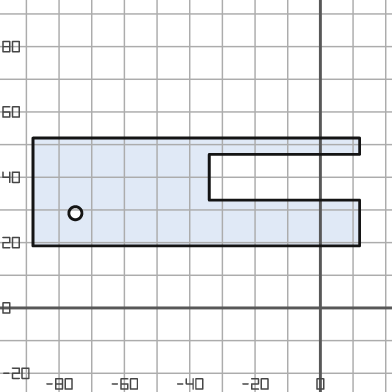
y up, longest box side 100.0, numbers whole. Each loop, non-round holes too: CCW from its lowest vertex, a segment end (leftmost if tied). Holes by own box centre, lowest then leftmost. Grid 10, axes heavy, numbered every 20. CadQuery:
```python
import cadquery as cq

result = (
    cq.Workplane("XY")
    .moveTo(-88.0, 19.0)
    .lineTo(12.0, 19.0)
    .lineTo(12.0, 33.0)
    .lineTo(-34.0, 33.0)
    .lineTo(-34.0, 47.0)
    .lineTo(12.0, 47.0)
    .lineTo(12.0, 52.0)
    .lineTo(-88.0, 52.0)
    .close()
    .moveTo(-75.0, 29.0)
    .circle(2.0)
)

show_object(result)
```